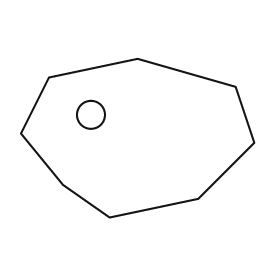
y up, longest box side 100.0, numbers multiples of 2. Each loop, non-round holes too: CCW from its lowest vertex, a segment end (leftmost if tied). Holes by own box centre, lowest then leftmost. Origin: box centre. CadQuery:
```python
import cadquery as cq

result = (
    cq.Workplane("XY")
    .moveTo(-12.0, -34.0)
    .lineTo(26.0, -26.0)
    .lineTo(50.0, -2.0)
    .lineTo(42.0, 22.0)
    .lineTo(0.0, 34.0)
    .lineTo(-38.0, 26.0)
    .lineTo(-50.0, 2.0)
    .lineTo(-32.0, -20.0)
    .close()
    .moveTo(-20.0, 10.0)
    .circle(6.0)
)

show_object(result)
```